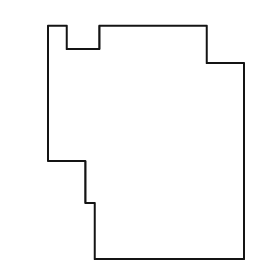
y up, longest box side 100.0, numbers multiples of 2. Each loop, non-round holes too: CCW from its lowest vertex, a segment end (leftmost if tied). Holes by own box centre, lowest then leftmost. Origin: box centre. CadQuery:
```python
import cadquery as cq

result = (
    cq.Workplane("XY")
    .moveTo(-22.0, -50.0)
    .lineTo(42.0, -50.0)
    .lineTo(42.0, 34.0)
    .lineTo(26.0, 34.0)
    .lineTo(26.0, 50.0)
    .lineTo(-20.0, 50.0)
    .lineTo(-20.0, 40.0)
    .lineTo(-34.0, 40.0)
    .lineTo(-34.0, 50.0)
    .lineTo(-42.0, 50.0)
    .lineTo(-42.0, -8.0)
    .lineTo(-26.0, -8.0)
    .lineTo(-26.0, -26.0)
    .lineTo(-22.0, -26.0)
    .close()
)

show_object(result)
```